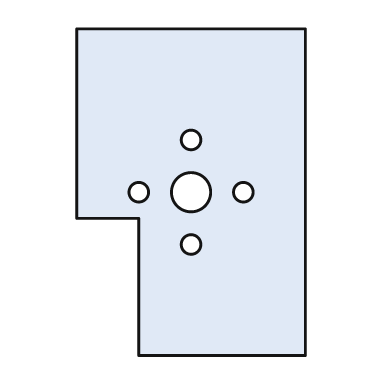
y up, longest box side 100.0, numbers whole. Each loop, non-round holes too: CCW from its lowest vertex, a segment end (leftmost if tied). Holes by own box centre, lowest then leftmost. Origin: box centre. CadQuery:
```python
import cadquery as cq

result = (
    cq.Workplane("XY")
    .moveTo(-16.0, -50.0)
    .lineTo(35.0, -50.0)
    .lineTo(35.0, 50.0)
    .lineTo(-35.0, 50.0)
    .lineTo(-35.0, -8.0)
    .lineTo(-16.0, -8.0)
    .close()
    .moveTo(0.0, -16.0)
    .circle(3.0)
    .moveTo(-16.0, 0.0)
    .circle(3.0)
    .moveTo(0.0, 0.0)
    .circle(6.0)
    .moveTo(16.0, 0.0)
    .circle(3.0)
    .moveTo(0.0, 16.0)
    .circle(3.0)
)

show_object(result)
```